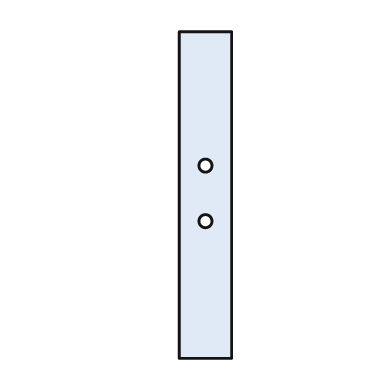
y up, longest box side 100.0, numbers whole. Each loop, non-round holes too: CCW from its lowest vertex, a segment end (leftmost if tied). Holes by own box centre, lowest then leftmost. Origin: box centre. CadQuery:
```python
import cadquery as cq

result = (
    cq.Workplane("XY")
    .moveTo(-8.0, -50.0)
    .lineTo(8.0, -50.0)
    .lineTo(8.0, 50.0)
    .lineTo(-8.0, 50.0)
    .close()
    .moveTo(0.0, -8.0)
    .circle(2.0)
    .moveTo(0.0, 9.0)
    .circle(2.0)
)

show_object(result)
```